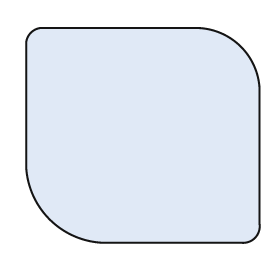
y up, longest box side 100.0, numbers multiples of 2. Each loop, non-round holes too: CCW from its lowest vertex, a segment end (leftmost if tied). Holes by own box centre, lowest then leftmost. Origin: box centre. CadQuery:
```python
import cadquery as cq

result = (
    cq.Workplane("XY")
    .moveTo(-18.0, -46.0)
    .lineTo(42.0, -46.0)
    .threePointArc((48.0, -44.0), (50.0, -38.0))
    .lineTo(50.0, 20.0)
    .threePointArc((42.0, 38.0), (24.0, 46.0))
    .lineTo(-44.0, 46.0)
    .threePointArc((-48.0, 44.0), (-50.0, 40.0))
    .lineTo(-50.0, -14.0)
    .threePointArc((-40.0, -36.0), (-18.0, -46.0))
    .close()
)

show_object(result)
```